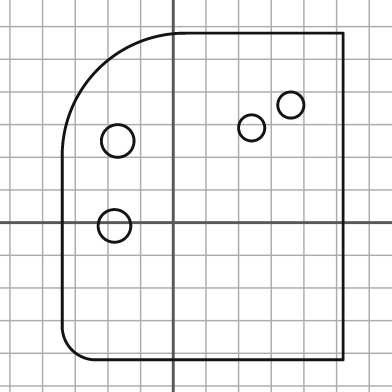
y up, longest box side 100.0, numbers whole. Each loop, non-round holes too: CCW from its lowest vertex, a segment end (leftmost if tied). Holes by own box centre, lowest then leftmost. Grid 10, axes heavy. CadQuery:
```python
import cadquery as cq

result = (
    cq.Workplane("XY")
    .moveTo(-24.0, -42.0)
    .lineTo(52.0, -42.0)
    .lineTo(52.0, 58.0)
    .lineTo(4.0, 58.0)
    .threePointArc((-23.0, 47.0), (-34.0, 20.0))
    .lineTo(-34.0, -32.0)
    .threePointArc((-31.0, -39.0), (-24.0, -42.0))
    .close()
    .moveTo(-18.0, -1.0)
    .circle(5.0)
    .moveTo(-17.0, 25.0)
    .circle(5.0)
    .moveTo(24.0, 29.0)
    .circle(4.0)
    .moveTo(36.0, 36.0)
    .circle(4.0)
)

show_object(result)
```